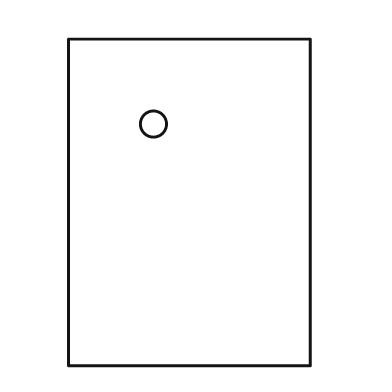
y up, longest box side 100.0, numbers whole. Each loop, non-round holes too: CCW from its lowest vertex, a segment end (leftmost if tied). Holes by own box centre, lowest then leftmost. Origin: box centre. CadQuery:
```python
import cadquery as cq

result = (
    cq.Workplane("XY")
    .moveTo(-37.0, -50.0)
    .lineTo(37.0, -50.0)
    .lineTo(37.0, 50.0)
    .lineTo(-37.0, 50.0)
    .close()
    .moveTo(-11.0, 24.0)
    .circle(4.0)
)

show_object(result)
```